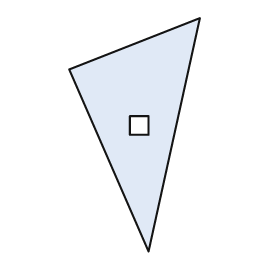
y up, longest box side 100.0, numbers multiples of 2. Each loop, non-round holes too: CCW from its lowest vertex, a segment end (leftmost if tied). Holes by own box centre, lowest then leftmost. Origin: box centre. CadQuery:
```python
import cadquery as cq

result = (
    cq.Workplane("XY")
    .moveTo(6.0, -50.0)
    .lineTo(28.0, 50.0)
    .lineTo(-28.0, 28.0)
    .close()
    .moveTo(-2.0, 0.0)
    .lineTo(6.0, 0.0)
    .lineTo(6.0, 8.0)
    .lineTo(-2.0, 8.0)
    .close()
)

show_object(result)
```